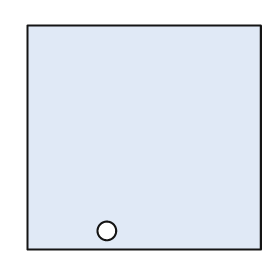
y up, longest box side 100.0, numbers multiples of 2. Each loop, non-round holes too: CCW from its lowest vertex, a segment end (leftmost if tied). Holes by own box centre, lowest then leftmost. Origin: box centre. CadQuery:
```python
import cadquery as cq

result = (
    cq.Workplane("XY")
    .moveTo(-50.0, -48.0)
    .lineTo(50.0, -48.0)
    .lineTo(50.0, 48.0)
    .lineTo(-50.0, 48.0)
    .close()
    .moveTo(-16.0, -40.0)
    .circle(4.0)
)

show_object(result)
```